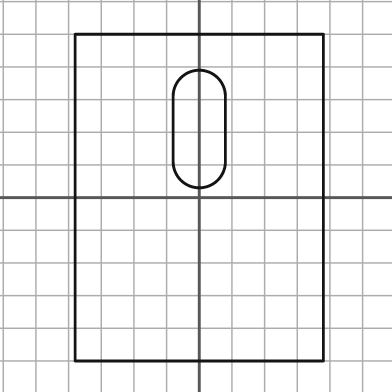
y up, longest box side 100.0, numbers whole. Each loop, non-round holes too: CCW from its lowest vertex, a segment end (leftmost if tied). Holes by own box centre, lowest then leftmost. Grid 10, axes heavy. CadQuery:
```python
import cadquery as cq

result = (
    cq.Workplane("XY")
    .moveTo(-38.0, -50.0)
    .lineTo(38.0, -50.0)
    .lineTo(38.0, 50.0)
    .lineTo(-38.0, 50.0)
    .close()
    .moveTo(-8.0, 11.0)
    .threePointArc((0.0, 3.0), (8.0, 11.0))
    .lineTo(8.0, 31.0)
    .threePointArc((0.0, 39.0), (-8.0, 31.0))
    .close()
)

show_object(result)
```